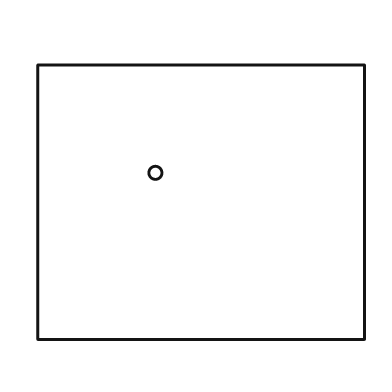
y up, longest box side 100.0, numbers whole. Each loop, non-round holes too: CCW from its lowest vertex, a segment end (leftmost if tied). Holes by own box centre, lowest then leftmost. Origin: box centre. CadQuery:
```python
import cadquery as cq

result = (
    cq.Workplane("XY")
    .moveTo(-50.0, -42.0)
    .lineTo(50.0, -42.0)
    .lineTo(50.0, 42.0)
    .lineTo(-50.0, 42.0)
    .close()
    .moveTo(-14.0, 9.0)
    .circle(2.0)
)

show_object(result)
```